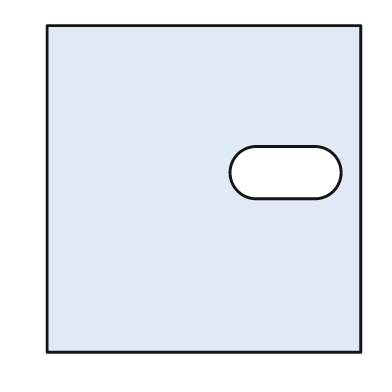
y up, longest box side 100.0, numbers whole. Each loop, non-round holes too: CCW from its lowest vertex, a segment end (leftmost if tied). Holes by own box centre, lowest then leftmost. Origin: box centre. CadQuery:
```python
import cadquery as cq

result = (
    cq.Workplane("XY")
    .moveTo(-48.0, -50.0)
    .lineTo(48.0, -50.0)
    .lineTo(48.0, 50.0)
    .lineTo(-48.0, 50.0)
    .close()
    .moveTo(16.0, -3.0)
    .lineTo(34.0, -3.0)
    .threePointArc((42.0, 5.0), (34.0, 13.0))
    .lineTo(16.0, 13.0)
    .threePointArc((8.0, 5.0), (16.0, -3.0))
    .close()
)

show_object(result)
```